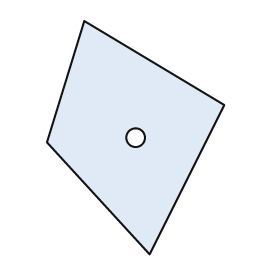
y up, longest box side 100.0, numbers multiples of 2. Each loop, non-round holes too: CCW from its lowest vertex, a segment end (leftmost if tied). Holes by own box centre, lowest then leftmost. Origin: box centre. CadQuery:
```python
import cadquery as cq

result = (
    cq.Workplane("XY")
    .moveTo(6.0, -50.0)
    .lineTo(38.0, 14.0)
    .lineTo(-22.0, 50.0)
    .lineTo(-38.0, -2.0)
    .close()
    .moveTo(0.0, 0.0)
    .circle(4.0)
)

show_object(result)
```